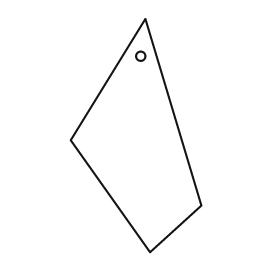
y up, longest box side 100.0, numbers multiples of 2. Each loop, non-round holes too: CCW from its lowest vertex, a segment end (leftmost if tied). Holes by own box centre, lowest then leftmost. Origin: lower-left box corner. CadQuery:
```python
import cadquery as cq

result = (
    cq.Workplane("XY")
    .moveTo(34.0, 0.0)
    .lineTo(56.0, 20.0)
    .lineTo(32.0, 100.0)
    .lineTo(0.0, 48.0)
    .close()
    .moveTo(30.0, 84.0)
    .circle(2.0)
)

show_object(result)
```